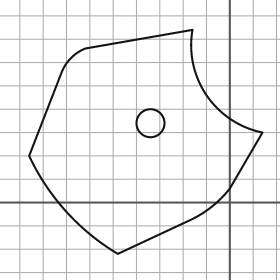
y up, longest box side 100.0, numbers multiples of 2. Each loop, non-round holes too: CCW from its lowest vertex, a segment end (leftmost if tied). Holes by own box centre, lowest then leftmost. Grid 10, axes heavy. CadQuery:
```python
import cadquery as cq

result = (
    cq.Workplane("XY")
    .moveTo(-48.0, -22.0)
    .lineTo(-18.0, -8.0)
    .threePointArc((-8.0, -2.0), (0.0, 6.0))
    .lineTo(14.0, 30.0)
    .threePointArc((-10.0, 46.0), (-16.0, 74.0))
    .lineTo(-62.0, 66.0)
    .threePointArc((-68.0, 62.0), (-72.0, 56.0))
    .lineTo(-86.0, 20.0)
    .threePointArc((-70.0, -4.0), (-48.0, -22.0))
    .close()
    .moveTo(-34.0, 34.0)
    .circle(6.0)
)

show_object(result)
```